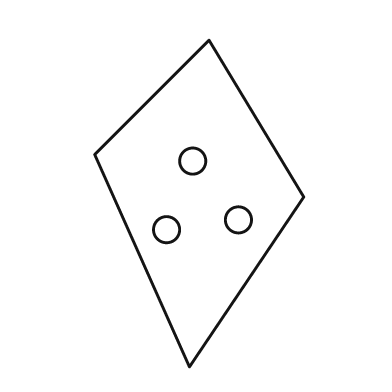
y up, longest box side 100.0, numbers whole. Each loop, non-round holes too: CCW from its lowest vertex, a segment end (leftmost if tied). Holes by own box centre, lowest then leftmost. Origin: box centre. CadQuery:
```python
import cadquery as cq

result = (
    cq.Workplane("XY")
    .moveTo(-3.0, -50.0)
    .lineTo(32.0, 2.0)
    .lineTo(3.0, 50.0)
    .lineTo(-32.0, 15.0)
    .close()
    .moveTo(-10.0, -8.0)
    .circle(4.0)
    .moveTo(12.0, -5.0)
    .circle(4.0)
    .moveTo(-2.0, 13.0)
    .circle(4.0)
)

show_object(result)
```